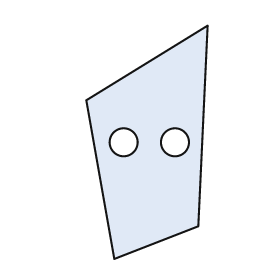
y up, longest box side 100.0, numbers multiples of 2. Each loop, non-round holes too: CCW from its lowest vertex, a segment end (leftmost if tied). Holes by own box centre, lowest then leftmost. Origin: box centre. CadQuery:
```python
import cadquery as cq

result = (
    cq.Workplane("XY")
    .moveTo(-14.0, -50.0)
    .lineTo(22.0, -36.0)
    .lineTo(26.0, 50.0)
    .lineTo(-26.0, 18.0)
    .close()
    .moveTo(-10.0, 0.0)
    .circle(6.0)
    .moveTo(12.0, 0.0)
    .circle(6.0)
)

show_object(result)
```